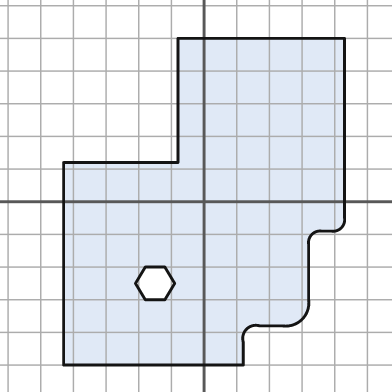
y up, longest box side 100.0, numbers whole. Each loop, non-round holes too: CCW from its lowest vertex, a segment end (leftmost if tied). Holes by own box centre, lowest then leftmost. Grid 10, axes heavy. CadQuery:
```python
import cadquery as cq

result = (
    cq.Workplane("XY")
    .moveTo(-43.0, -50.0)
    .lineTo(12.0, -50.0)
    .lineTo(12.0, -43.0)
    .threePointArc((13.0, -39.0), (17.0, -38.0))
    .lineTo(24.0, -38.0)
    .threePointArc((30.0, -36.0), (32.0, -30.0))
    .lineTo(32.0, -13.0)
    .threePointArc((33.0, -10.0), (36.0, -9.0))
    .lineTo(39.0, -9.0)
    .threePointArc((42.0, -8.0), (43.0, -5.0))
    .lineTo(43.0, 50.0)
    .lineTo(-8.0, 50.0)
    .lineTo(-8.0, 12.0)
    .lineTo(-43.0, 12.0)
    .close()
    .moveTo(-18.0, -30.0)
    .lineTo(-12.0, -30.0)
    .lineTo(-9.0, -25.0)
    .lineTo(-12.0, -20.0)
    .lineTo(-18.0, -20.0)
    .lineTo(-21.0, -25.0)
    .close()
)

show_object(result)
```